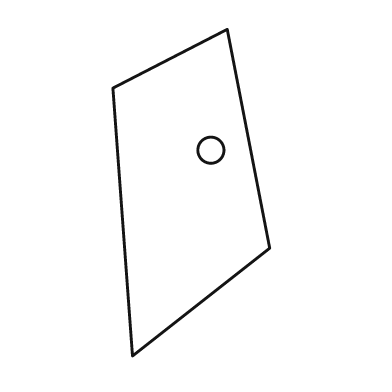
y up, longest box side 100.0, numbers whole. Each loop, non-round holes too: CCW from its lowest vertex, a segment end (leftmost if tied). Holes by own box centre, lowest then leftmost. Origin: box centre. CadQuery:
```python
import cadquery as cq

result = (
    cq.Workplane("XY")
    .moveTo(-18.0, -50.0)
    .lineTo(24.0, -17.0)
    .lineTo(11.0, 50.0)
    .lineTo(-24.0, 32.0)
    .close()
    .moveTo(6.0, 13.0)
    .circle(4.0)
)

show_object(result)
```